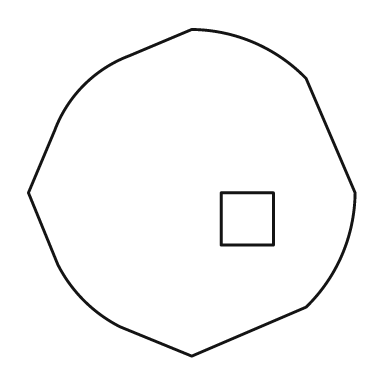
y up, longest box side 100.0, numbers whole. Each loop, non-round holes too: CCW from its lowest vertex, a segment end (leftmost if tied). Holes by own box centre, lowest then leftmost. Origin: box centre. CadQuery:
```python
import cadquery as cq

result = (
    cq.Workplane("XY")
    .moveTo(0.0, -50.0)
    .lineTo(35.0, -35.0)
    .threePointArc((46.0, -19.0), (50.0, 0.0))
    .lineTo(35.0, 35.0)
    .threePointArc((19.0, 46.0), (0.0, 50.0))
    .lineTo(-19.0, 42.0)
    .threePointArc((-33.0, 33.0), (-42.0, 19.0))
    .lineTo(-50.0, 0.0)
    .lineTo(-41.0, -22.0)
    .threePointArc((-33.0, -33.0), (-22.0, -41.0))
    .close()
    .moveTo(9.0, -16.0)
    .lineTo(25.0, -16.0)
    .lineTo(25.0, 0.0)
    .lineTo(9.0, 0.0)
    .close()
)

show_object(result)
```